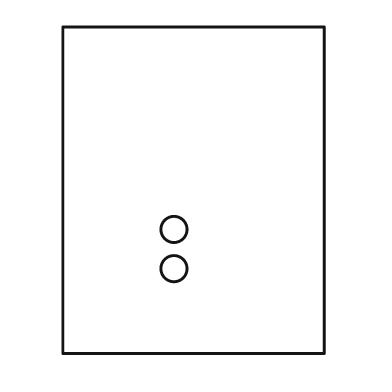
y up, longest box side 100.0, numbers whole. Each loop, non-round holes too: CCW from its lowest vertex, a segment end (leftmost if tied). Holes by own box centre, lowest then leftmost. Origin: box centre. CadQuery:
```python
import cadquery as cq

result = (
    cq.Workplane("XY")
    .moveTo(-40.0, -50.0)
    .lineTo(40.0, -50.0)
    .lineTo(40.0, 50.0)
    .lineTo(-40.0, 50.0)
    .close()
    .moveTo(-6.0, -24.0)
    .circle(4.0)
    .moveTo(-6.0, -12.0)
    .circle(4.0)
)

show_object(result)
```